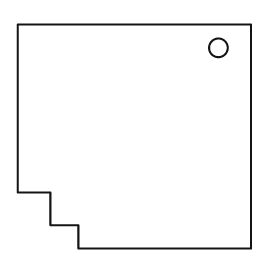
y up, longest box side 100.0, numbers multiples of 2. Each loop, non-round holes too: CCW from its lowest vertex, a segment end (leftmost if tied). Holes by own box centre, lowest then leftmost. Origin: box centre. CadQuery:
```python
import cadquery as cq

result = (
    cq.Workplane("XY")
    .moveTo(-24.0, -48.0)
    .lineTo(50.0, -48.0)
    .lineTo(50.0, 48.0)
    .lineTo(-50.0, 48.0)
    .lineTo(-50.0, -24.0)
    .lineTo(-36.0, -24.0)
    .lineTo(-36.0, -38.0)
    .lineTo(-24.0, -38.0)
    .close()
    .moveTo(36.0, 38.0)
    .circle(4.0)
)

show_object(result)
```